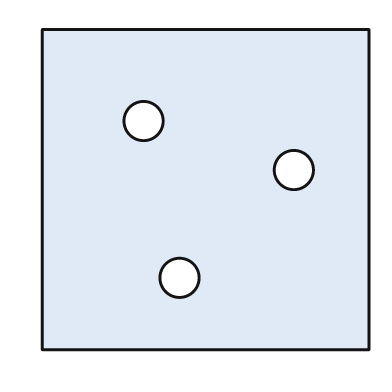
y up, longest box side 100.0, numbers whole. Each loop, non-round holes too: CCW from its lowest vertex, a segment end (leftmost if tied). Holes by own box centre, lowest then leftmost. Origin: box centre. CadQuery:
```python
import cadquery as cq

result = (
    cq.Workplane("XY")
    .moveTo(-50.0, -49.0)
    .lineTo(50.0, -49.0)
    .lineTo(50.0, 49.0)
    .lineTo(-50.0, 49.0)
    .close()
    .moveTo(-8.0, -27.0)
    .circle(6.0)
    .moveTo(27.0, 6.0)
    .circle(6.0)
    .moveTo(-19.0, 21.0)
    .circle(6.0)
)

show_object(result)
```